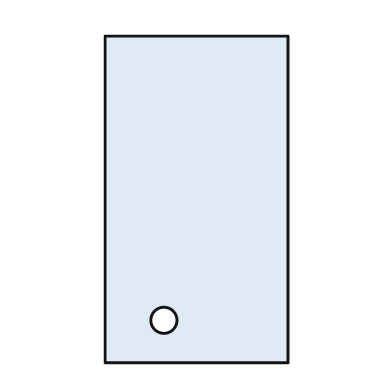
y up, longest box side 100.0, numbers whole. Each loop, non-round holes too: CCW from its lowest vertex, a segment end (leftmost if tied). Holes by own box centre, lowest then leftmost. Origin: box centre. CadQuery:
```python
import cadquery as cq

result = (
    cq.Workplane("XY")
    .moveTo(-28.0, -50.0)
    .lineTo(28.0, -50.0)
    .lineTo(28.0, 50.0)
    .lineTo(-28.0, 50.0)
    .close()
    .moveTo(-10.0, -37.0)
    .circle(4.0)
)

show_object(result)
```